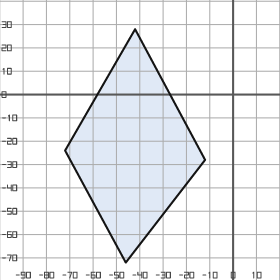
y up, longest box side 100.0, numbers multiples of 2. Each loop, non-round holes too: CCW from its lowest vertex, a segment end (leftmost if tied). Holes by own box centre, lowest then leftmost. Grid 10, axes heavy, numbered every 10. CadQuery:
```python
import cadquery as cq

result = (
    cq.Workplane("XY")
    .moveTo(-46.0, -72.0)
    .lineTo(-12.0, -28.0)
    .lineTo(-42.0, 28.0)
    .lineTo(-72.0, -24.0)
    .close()
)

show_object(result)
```